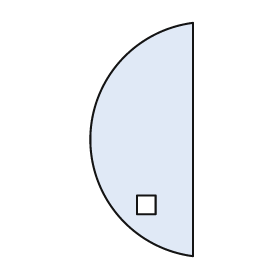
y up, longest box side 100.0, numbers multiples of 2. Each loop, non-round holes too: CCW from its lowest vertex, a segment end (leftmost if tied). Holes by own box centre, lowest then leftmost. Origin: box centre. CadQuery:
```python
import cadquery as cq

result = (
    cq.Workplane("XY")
    .moveTo(22.0, -50.0)
    .lineTo(22.0, 50.0)
    .threePointArc((-22.0, 0.0), (22.0, -50.0))
    .close()
    .moveTo(-2.0, -32.0)
    .lineTo(6.0, -32.0)
    .lineTo(6.0, -24.0)
    .lineTo(-2.0, -24.0)
    .close()
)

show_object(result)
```